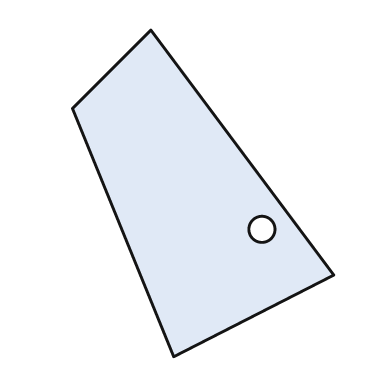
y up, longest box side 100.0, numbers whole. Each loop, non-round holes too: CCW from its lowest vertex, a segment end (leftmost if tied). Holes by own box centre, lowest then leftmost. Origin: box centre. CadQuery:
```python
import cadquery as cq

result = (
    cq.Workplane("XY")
    .moveTo(-9.0, -50.0)
    .lineTo(40.0, -25.0)
    .lineTo(-16.0, 50.0)
    .lineTo(-40.0, 26.0)
    .close()
    .moveTo(18.0, -11.0)
    .circle(4.0)
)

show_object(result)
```